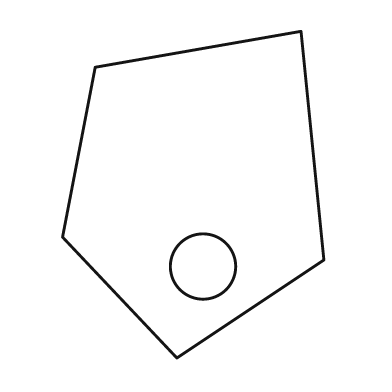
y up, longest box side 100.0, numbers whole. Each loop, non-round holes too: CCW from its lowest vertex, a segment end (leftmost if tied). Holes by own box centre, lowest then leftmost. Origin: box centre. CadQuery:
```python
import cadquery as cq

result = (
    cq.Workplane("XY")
    .moveTo(-5.0, -50.0)
    .lineTo(40.0, -20.0)
    .lineTo(33.0, 50.0)
    .lineTo(-30.0, 39.0)
    .lineTo(-40.0, -13.0)
    .close()
    .moveTo(3.0, -22.0)
    .circle(10.0)
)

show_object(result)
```